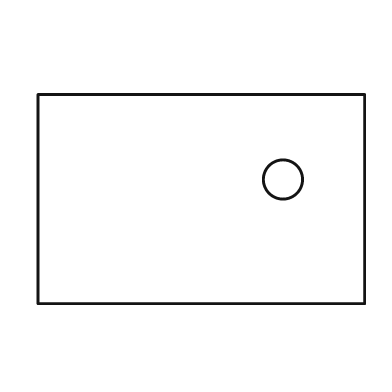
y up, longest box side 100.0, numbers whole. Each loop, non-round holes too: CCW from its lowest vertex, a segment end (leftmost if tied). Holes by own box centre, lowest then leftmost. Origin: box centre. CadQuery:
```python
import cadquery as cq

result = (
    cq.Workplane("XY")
    .moveTo(-50.0, -32.0)
    .lineTo(50.0, -32.0)
    .lineTo(50.0, 32.0)
    .lineTo(-50.0, 32.0)
    .close()
    .moveTo(25.0, 6.0)
    .circle(6.0)
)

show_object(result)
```